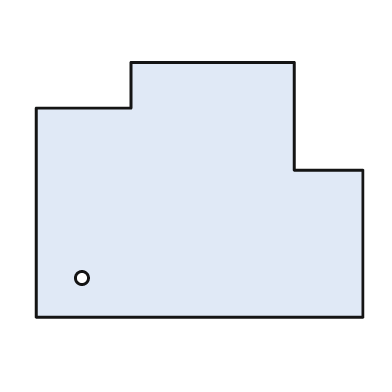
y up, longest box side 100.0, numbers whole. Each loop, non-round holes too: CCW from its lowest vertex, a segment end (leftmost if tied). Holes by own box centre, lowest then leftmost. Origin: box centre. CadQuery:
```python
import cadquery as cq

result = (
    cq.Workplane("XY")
    .moveTo(-50.0, -39.0)
    .lineTo(50.0, -39.0)
    .lineTo(50.0, 6.0)
    .lineTo(29.0, 6.0)
    .lineTo(29.0, 39.0)
    .lineTo(-21.0, 39.0)
    .lineTo(-21.0, 25.0)
    .lineTo(-50.0, 25.0)
    .close()
    .moveTo(-36.0, -27.0)
    .circle(2.0)
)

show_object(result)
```